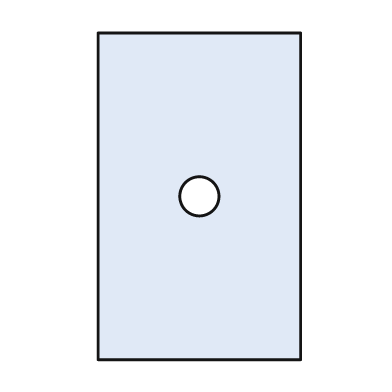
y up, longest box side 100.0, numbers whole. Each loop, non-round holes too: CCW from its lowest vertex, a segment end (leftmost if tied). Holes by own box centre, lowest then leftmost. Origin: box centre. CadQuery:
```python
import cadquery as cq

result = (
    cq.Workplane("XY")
    .moveTo(-31.0, -50.0)
    .lineTo(31.0, -50.0)
    .lineTo(31.0, 50.0)
    .lineTo(-31.0, 50.0)
    .close()
    .moveTo(0.0, 0.0)
    .circle(6.0)
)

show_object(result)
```